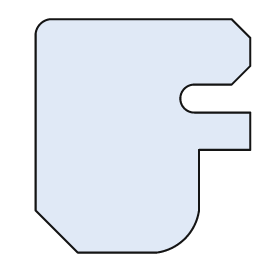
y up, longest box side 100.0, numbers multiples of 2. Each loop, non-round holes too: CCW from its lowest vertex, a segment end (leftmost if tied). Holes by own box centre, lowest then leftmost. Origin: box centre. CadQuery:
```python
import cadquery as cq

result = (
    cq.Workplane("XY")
    .moveTo(-28.0, -50.0)
    .lineTo(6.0, -50.0)
    .threePointArc((18.0, -44.0), (24.0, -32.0))
    .lineTo(24.0, -6.0)
    .lineTo(46.0, -6.0)
    .lineTo(46.0, 10.0)
    .lineTo(22.0, 10.0)
    .threePointArc((16.0, 16.0), (22.0, 22.0))
    .lineTo(38.0, 22.0)
    .lineTo(46.0, 30.0)
    .lineTo(46.0, 42.0)
    .lineTo(38.0, 50.0)
    .lineTo(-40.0, 50.0)
    .threePointArc((-44.0, 48.0), (-46.0, 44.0))
    .lineTo(-46.0, -32.0)
    .close()
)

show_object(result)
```